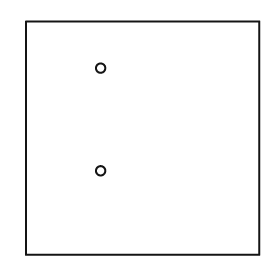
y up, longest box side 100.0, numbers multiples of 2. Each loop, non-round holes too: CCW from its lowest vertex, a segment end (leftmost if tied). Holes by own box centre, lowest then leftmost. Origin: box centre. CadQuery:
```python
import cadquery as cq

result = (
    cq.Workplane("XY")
    .moveTo(-50.0, -50.0)
    .lineTo(50.0, -50.0)
    .lineTo(50.0, 50.0)
    .lineTo(-50.0, 50.0)
    .close()
    .moveTo(-18.0, -14.0)
    .circle(2.0)
    .moveTo(-18.0, 30.0)
    .circle(2.0)
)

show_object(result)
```